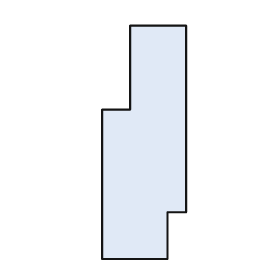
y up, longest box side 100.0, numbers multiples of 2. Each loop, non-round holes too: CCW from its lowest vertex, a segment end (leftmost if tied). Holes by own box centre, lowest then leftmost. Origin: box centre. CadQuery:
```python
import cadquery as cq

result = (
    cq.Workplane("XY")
    .moveTo(-18.0, -50.0)
    .lineTo(10.0, -50.0)
    .lineTo(10.0, -30.0)
    .lineTo(18.0, -30.0)
    .lineTo(18.0, 50.0)
    .lineTo(-6.0, 50.0)
    .lineTo(-6.0, 14.0)
    .lineTo(-18.0, 14.0)
    .close()
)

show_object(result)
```